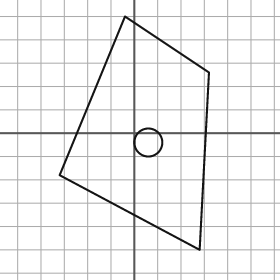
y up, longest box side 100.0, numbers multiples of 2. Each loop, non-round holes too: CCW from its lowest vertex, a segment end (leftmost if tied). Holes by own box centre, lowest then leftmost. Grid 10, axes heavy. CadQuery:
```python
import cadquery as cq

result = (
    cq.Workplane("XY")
    .moveTo(28.0, -50.0)
    .lineTo(32.0, 26.0)
    .lineTo(-4.0, 50.0)
    .lineTo(-32.0, -18.0)
    .close()
    .moveTo(6.0, -4.0)
    .circle(6.0)
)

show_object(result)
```